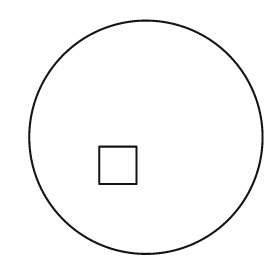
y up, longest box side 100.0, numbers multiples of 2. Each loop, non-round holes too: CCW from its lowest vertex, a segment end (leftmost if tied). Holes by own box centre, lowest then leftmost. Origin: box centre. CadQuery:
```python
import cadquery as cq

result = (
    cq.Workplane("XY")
    .moveTo(0.0, 0.0)
    .circle(50.0)
    .moveTo(-20.0, -20.0)
    .lineTo(-4.0, -20.0)
    .lineTo(-4.0, -4.0)
    .lineTo(-20.0, -4.0)
    .close()
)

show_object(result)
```